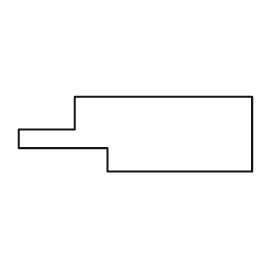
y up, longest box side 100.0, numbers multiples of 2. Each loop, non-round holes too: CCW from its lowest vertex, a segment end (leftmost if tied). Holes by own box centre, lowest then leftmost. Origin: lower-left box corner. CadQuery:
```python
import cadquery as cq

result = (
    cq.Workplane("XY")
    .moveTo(38.0, 0.0)
    .lineTo(100.0, 0.0)
    .lineTo(100.0, 32.0)
    .lineTo(24.0, 32.0)
    .lineTo(24.0, 18.0)
    .lineTo(0.0, 18.0)
    .lineTo(0.0, 10.0)
    .lineTo(38.0, 10.0)
    .close()
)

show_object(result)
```